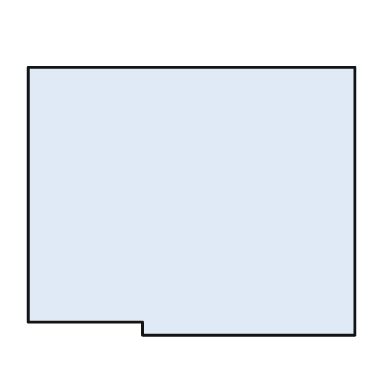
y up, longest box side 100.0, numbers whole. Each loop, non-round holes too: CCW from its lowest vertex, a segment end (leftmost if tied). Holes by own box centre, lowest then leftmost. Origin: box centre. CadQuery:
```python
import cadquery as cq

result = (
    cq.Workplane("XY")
    .moveTo(-15.0, -41.0)
    .lineTo(50.0, -41.0)
    .lineTo(50.0, 41.0)
    .lineTo(-50.0, 41.0)
    .lineTo(-50.0, -37.0)
    .lineTo(-15.0, -37.0)
    .close()
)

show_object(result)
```